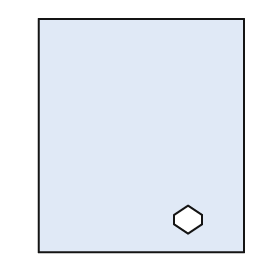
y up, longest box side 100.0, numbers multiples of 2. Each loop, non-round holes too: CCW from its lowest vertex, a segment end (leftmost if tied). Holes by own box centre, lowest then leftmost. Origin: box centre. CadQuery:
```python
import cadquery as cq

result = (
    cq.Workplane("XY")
    .moveTo(-44.0, -50.0)
    .lineTo(44.0, -50.0)
    .lineTo(44.0, 50.0)
    .lineTo(-44.0, 50.0)
    .close()
    .moveTo(20.0, -42.0)
    .lineTo(26.0, -38.0)
    .lineTo(26.0, -34.0)
    .lineTo(20.0, -30.0)
    .lineTo(14.0, -34.0)
    .lineTo(14.0, -38.0)
    .close()
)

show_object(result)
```